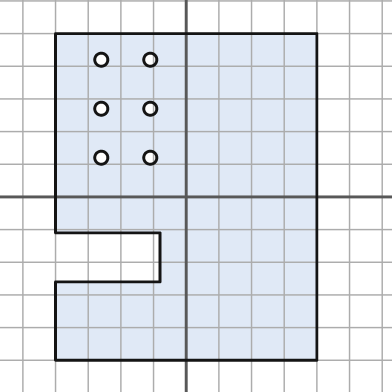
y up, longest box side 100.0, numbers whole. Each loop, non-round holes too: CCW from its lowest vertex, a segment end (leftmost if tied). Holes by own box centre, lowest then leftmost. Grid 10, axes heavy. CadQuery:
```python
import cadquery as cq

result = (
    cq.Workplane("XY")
    .moveTo(-40.0, -50.0)
    .lineTo(40.0, -50.0)
    .lineTo(40.0, 50.0)
    .lineTo(-40.0, 50.0)
    .lineTo(-40.0, -11.0)
    .lineTo(-8.0, -11.0)
    .lineTo(-8.0, -26.0)
    .lineTo(-40.0, -26.0)
    .close()
    .moveTo(-26.0, 12.0)
    .circle(2.0)
    .moveTo(-11.0, 12.0)
    .circle(2.0)
    .moveTo(-26.0, 27.0)
    .circle(2.0)
    .moveTo(-11.0, 27.0)
    .circle(2.0)
    .moveTo(-26.0, 42.0)
    .circle(2.0)
    .moveTo(-11.0, 42.0)
    .circle(2.0)
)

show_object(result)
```